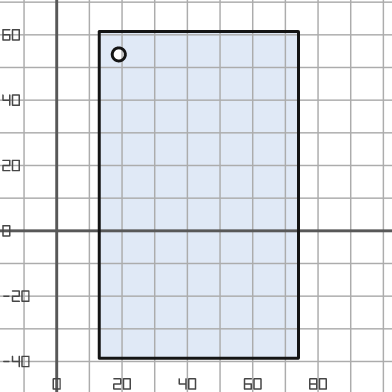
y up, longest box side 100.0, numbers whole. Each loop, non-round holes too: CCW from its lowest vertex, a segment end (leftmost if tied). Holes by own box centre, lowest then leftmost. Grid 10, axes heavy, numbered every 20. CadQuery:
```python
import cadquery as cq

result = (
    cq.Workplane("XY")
    .moveTo(13.0, -39.0)
    .lineTo(74.0, -39.0)
    .lineTo(74.0, 61.0)
    .lineTo(13.0, 61.0)
    .close()
    .moveTo(19.0, 54.0)
    .circle(2.0)
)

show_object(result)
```